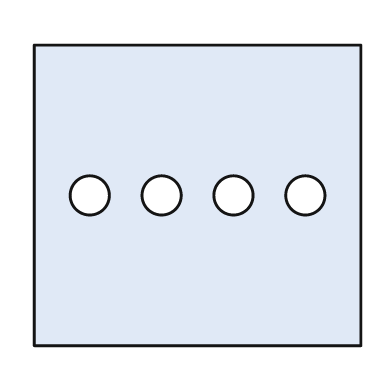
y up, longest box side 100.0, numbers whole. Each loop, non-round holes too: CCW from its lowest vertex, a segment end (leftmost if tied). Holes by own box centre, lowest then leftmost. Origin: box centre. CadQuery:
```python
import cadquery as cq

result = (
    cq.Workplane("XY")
    .moveTo(-50.0, -46.0)
    .lineTo(50.0, -46.0)
    .lineTo(50.0, 46.0)
    .lineTo(-50.0, 46.0)
    .close()
    .moveTo(-33.0, 0.0)
    .circle(6.0)
    .moveTo(-11.0, 0.0)
    .circle(6.0)
    .moveTo(11.0, 0.0)
    .circle(6.0)
    .moveTo(33.0, 0.0)
    .circle(6.0)
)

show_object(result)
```